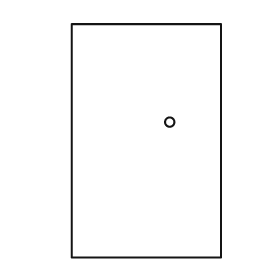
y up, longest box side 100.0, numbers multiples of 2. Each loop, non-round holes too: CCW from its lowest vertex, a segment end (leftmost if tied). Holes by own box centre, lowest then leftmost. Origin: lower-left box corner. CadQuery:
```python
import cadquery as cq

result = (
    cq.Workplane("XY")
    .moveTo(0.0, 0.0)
    .lineTo(64.0, 0.0)
    .lineTo(64.0, 100.0)
    .lineTo(0.0, 100.0)
    .close()
    .moveTo(42.0, 58.0)
    .circle(2.0)
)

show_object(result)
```